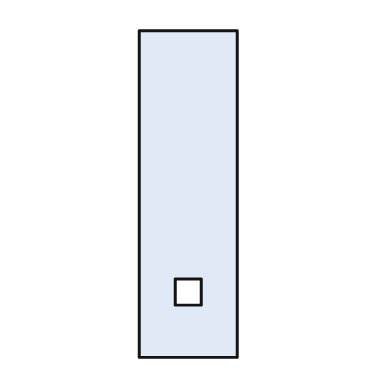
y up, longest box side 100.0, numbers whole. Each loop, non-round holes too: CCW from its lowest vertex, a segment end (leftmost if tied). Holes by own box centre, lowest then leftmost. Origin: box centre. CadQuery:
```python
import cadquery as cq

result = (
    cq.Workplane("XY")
    .moveTo(-15.0, -50.0)
    .lineTo(15.0, -50.0)
    .lineTo(15.0, 50.0)
    .lineTo(-15.0, 50.0)
    .close()
    .moveTo(-4.0, -34.0)
    .lineTo(4.0, -34.0)
    .lineTo(4.0, -26.0)
    .lineTo(-4.0, -26.0)
    .close()
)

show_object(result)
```